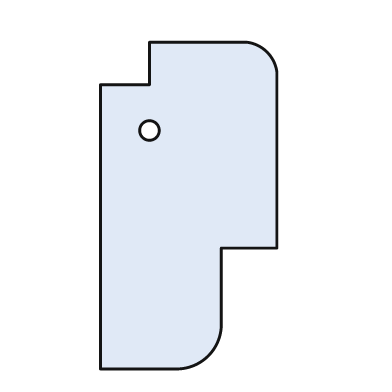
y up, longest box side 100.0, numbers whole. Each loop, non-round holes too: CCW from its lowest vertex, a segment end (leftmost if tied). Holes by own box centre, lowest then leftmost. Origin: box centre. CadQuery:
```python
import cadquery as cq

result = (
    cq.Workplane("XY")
    .moveTo(-27.0, -50.0)
    .lineTo(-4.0, -50.0)
    .threePointArc((6.0, -46.0), (10.0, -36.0))
    .lineTo(10.0, -13.0)
    .lineTo(27.0, -13.0)
    .lineTo(27.0, 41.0)
    .threePointArc((24.0, 47.0), (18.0, 50.0))
    .lineTo(-12.0, 50.0)
    .lineTo(-12.0, 37.0)
    .lineTo(-27.0, 37.0)
    .close()
    .moveTo(-12.0, 23.0)
    .circle(3.0)
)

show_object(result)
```